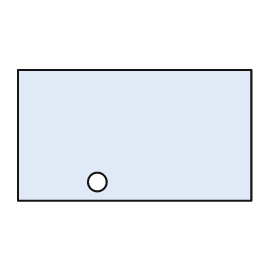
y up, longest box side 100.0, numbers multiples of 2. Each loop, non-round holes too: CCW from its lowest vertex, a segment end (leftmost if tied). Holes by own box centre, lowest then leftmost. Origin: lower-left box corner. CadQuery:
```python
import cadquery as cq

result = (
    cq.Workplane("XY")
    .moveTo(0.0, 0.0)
    .lineTo(100.0, 0.0)
    .lineTo(100.0, 56.0)
    .lineTo(0.0, 56.0)
    .close()
    .moveTo(34.0, 8.0)
    .circle(4.0)
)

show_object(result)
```